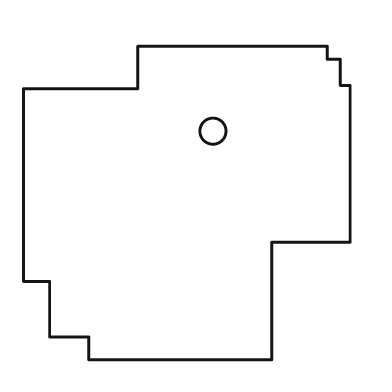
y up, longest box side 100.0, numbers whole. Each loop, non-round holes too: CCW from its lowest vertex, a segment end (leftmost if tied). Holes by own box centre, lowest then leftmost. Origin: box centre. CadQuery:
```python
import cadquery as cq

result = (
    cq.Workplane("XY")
    .moveTo(-30.0, -48.0)
    .lineTo(26.0, -48.0)
    .lineTo(26.0, -12.0)
    .lineTo(50.0, -12.0)
    .lineTo(50.0, 36.0)
    .lineTo(47.0, 36.0)
    .lineTo(47.0, 44.0)
    .lineTo(43.0, 44.0)
    .lineTo(43.0, 48.0)
    .lineTo(-15.0, 48.0)
    .lineTo(-15.0, 35.0)
    .lineTo(-50.0, 35.0)
    .lineTo(-50.0, -24.0)
    .lineTo(-42.0, -24.0)
    .lineTo(-42.0, -41.0)
    .lineTo(-30.0, -41.0)
    .close()
    .moveTo(8.0, 22.0)
    .circle(4.0)
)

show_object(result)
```